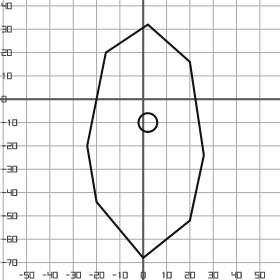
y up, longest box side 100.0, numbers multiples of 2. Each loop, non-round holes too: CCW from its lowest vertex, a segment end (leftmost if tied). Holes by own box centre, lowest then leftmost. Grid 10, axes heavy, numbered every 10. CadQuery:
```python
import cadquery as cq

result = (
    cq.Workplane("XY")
    .moveTo(0.0, -68.0)
    .lineTo(20.0, -52.0)
    .lineTo(26.0, -24.0)
    .lineTo(20.0, 16.0)
    .lineTo(2.0, 32.0)
    .lineTo(-16.0, 20.0)
    .lineTo(-24.0, -20.0)
    .lineTo(-20.0, -44.0)
    .close()
    .moveTo(2.0, -10.0)
    .circle(4.0)
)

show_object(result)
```